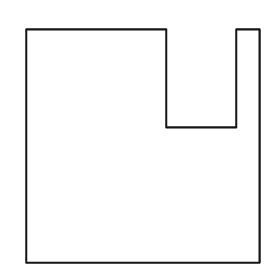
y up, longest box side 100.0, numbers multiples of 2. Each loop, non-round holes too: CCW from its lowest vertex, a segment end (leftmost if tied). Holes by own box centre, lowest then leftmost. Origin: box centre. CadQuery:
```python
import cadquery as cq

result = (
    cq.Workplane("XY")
    .moveTo(-50.0, -50.0)
    .lineTo(50.0, -50.0)
    .lineTo(50.0, 50.0)
    .lineTo(40.0, 50.0)
    .lineTo(40.0, 8.0)
    .lineTo(10.0, 8.0)
    .lineTo(10.0, 50.0)
    .lineTo(-50.0, 50.0)
    .close()
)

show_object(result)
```